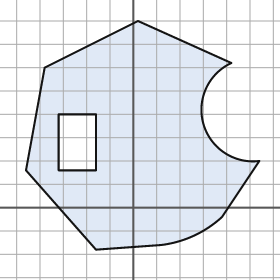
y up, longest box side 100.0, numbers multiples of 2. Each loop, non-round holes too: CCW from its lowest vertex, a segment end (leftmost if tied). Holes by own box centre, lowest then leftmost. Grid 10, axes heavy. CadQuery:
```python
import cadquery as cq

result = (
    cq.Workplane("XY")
    .moveTo(-16.0, -18.0)
    .lineTo(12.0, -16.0)
    .threePointArc((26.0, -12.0), (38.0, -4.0))
    .lineTo(54.0, 20.0)
    .threePointArc((30.0, 36.0), (42.0, 62.0))
    .lineTo(2.0, 80.0)
    .lineTo(-38.0, 60.0)
    .lineTo(-46.0, 16.0)
    .close()
    .moveTo(-32.0, 16.0)
    .lineTo(-16.0, 16.0)
    .lineTo(-16.0, 40.0)
    .lineTo(-32.0, 40.0)
    .close()
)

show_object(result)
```